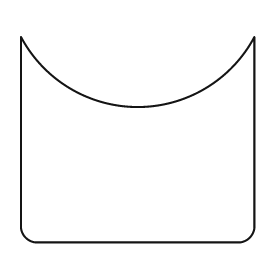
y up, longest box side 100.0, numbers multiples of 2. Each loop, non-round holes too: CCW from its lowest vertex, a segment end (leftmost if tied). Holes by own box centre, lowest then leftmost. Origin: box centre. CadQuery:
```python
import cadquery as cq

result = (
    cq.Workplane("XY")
    .moveTo(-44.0, -44.0)
    .lineTo(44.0, -44.0)
    .threePointArc((48.0, -42.0), (50.0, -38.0))
    .lineTo(50.0, 44.0)
    .threePointArc((0.0, 14.0), (-50.0, 44.0))
    .lineTo(-50.0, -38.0)
    .threePointArc((-48.0, -42.0), (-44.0, -44.0))
    .close()
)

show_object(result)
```